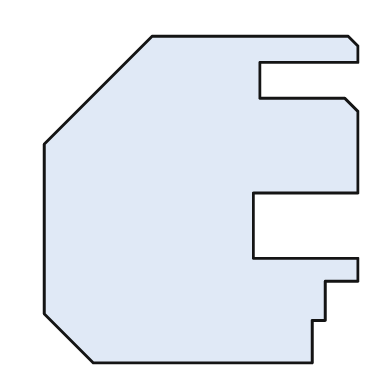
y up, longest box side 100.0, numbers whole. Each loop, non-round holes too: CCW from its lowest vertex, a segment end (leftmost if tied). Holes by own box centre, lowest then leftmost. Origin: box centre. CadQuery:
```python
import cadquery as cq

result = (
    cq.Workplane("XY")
    .moveTo(-33.0, -50.0)
    .lineTo(34.0, -50.0)
    .lineTo(34.0, -37.0)
    .lineTo(38.0, -37.0)
    .lineTo(38.0, -25.0)
    .lineTo(48.0, -25.0)
    .lineTo(48.0, -18.0)
    .lineTo(16.0, -18.0)
    .lineTo(16.0, 2.0)
    .lineTo(48.0, 2.0)
    .lineTo(48.0, 27.0)
    .lineTo(44.0, 31.0)
    .lineTo(18.0, 31.0)
    .lineTo(18.0, 42.0)
    .lineTo(48.0, 42.0)
    .lineTo(48.0, 47.0)
    .lineTo(45.0, 50.0)
    .lineTo(-15.0, 50.0)
    .lineTo(-48.0, 17.0)
    .lineTo(-48.0, -35.0)
    .close()
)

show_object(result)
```